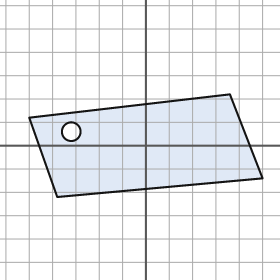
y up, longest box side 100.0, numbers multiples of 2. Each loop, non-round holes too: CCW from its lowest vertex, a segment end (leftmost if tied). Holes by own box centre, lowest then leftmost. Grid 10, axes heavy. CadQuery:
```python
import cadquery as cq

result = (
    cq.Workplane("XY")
    .moveTo(-38.0, -22.0)
    .lineTo(50.0, -14.0)
    .lineTo(36.0, 22.0)
    .lineTo(-50.0, 12.0)
    .close()
    .moveTo(-32.0, 6.0)
    .circle(4.0)
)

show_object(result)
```